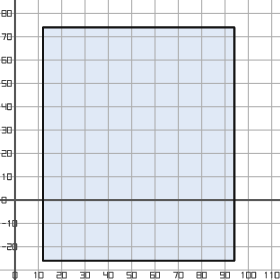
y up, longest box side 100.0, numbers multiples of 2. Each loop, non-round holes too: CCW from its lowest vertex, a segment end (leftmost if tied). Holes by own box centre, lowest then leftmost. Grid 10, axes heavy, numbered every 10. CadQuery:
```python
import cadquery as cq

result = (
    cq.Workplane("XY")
    .moveTo(12.0, -26.0)
    .lineTo(94.0, -26.0)
    .lineTo(94.0, 74.0)
    .lineTo(12.0, 74.0)
    .close()
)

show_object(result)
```